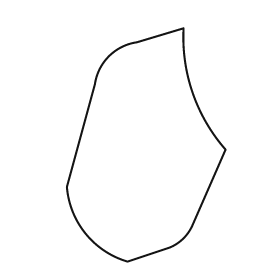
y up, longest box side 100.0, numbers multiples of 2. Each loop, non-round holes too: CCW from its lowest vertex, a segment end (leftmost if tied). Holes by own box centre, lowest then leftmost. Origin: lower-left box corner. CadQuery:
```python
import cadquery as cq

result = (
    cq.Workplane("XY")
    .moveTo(26.0, 0.0)
    .lineTo(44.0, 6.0)
    .threePointArc((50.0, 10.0), (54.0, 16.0))
    .lineTo(68.0, 48.0)
    .threePointArc((54.0, 72.0), (50.0, 100.0))
    .lineTo(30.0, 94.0)
    .threePointArc((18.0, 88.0), (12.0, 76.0))
    .lineTo(0.0, 32.0)
    .threePointArc((8.0, 12.0), (26.0, 0.0))
    .close()
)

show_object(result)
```